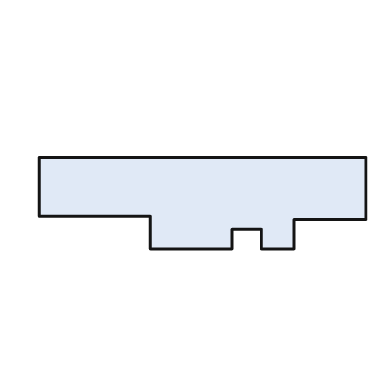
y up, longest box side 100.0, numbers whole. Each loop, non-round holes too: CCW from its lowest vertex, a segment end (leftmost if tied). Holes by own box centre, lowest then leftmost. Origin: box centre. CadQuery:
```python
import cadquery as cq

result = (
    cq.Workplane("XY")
    .moveTo(-16.0, -14.0)
    .lineTo(9.0, -14.0)
    .lineTo(9.0, -8.0)
    .lineTo(18.0, -8.0)
    .lineTo(18.0, -14.0)
    .lineTo(28.0, -14.0)
    .lineTo(28.0, -5.0)
    .lineTo(50.0, -5.0)
    .lineTo(50.0, 14.0)
    .lineTo(-50.0, 14.0)
    .lineTo(-50.0, -4.0)
    .lineTo(-16.0, -4.0)
    .close()
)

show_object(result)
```